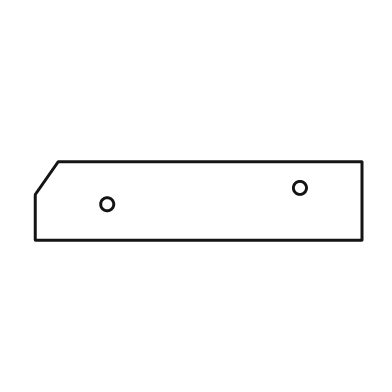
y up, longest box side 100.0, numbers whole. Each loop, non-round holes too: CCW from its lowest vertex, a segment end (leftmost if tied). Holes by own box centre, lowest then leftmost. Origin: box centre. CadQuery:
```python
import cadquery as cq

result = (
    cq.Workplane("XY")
    .moveTo(-50.0, -12.0)
    .lineTo(50.0, -12.0)
    .lineTo(50.0, 12.0)
    .lineTo(-43.0, 12.0)
    .lineTo(-50.0, 2.0)
    .close()
    .moveTo(-28.0, -1.0)
    .circle(2.0)
    .moveTo(31.0, 4.0)
    .circle(2.0)
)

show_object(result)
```